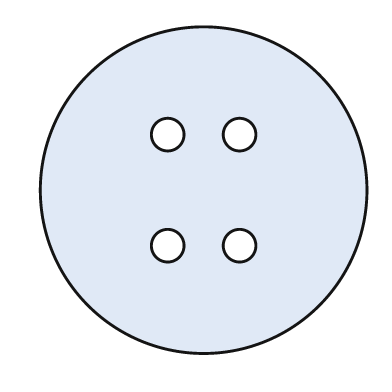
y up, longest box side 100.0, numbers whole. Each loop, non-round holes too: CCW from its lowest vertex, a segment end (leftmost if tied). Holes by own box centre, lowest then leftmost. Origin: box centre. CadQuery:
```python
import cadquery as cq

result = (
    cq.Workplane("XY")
    .moveTo(0.0, 0.0)
    .circle(50.0)
    .moveTo(-11.0, -17.0)
    .circle(5.0)
    .moveTo(11.0, -17.0)
    .circle(5.0)
    .moveTo(-11.0, 17.0)
    .circle(5.0)
    .moveTo(11.0, 17.0)
    .circle(5.0)
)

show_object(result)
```